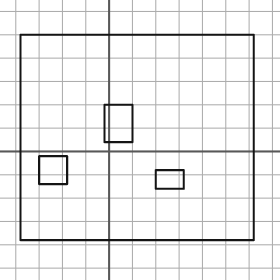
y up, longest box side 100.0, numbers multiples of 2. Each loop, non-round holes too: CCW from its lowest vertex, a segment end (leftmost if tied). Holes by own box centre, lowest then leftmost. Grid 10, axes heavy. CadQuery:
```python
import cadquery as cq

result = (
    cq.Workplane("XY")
    .moveTo(-38.0, -38.0)
    .lineTo(62.0, -38.0)
    .lineTo(62.0, 50.0)
    .lineTo(-38.0, 50.0)
    .close()
    .moveTo(20.0, -16.0)
    .lineTo(32.0, -16.0)
    .lineTo(32.0, -8.0)
    .lineTo(20.0, -8.0)
    .close()
    .moveTo(-30.0, -14.0)
    .lineTo(-18.0, -14.0)
    .lineTo(-18.0, -2.0)
    .lineTo(-30.0, -2.0)
    .close()
    .moveTo(-2.0, 4.0)
    .lineTo(10.0, 4.0)
    .lineTo(10.0, 20.0)
    .lineTo(-2.0, 20.0)
    .close()
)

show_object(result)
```